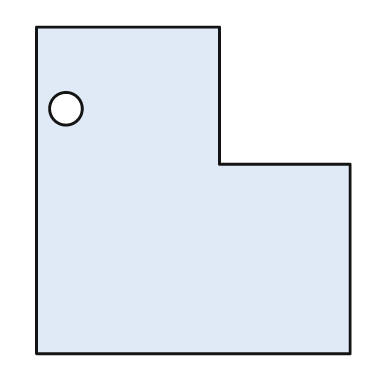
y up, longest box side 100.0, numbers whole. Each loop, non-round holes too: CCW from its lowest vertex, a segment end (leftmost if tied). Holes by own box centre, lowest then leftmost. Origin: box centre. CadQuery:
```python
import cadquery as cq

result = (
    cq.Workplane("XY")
    .moveTo(-48.0, -50.0)
    .lineTo(48.0, -50.0)
    .lineTo(48.0, 8.0)
    .lineTo(8.0, 8.0)
    .lineTo(8.0, 50.0)
    .lineTo(-48.0, 50.0)
    .close()
    .moveTo(-39.0, 25.0)
    .circle(5.0)
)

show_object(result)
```